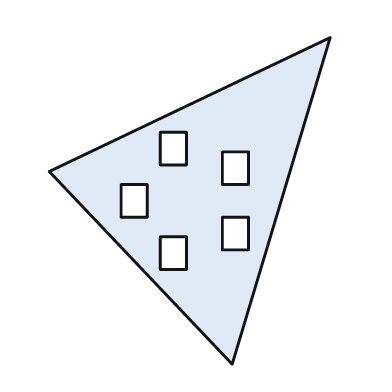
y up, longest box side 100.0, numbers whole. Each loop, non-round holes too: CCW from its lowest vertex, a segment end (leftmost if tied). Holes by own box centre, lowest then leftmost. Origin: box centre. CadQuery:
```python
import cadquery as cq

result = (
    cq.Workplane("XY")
    .moveTo(13.0, -50.0)
    .lineTo(43.0, 50.0)
    .lineTo(-43.0, 9.0)
    .close()
    .moveTo(-9.0, -21.0)
    .lineTo(-1.0, -21.0)
    .lineTo(-1.0, -11.0)
    .lineTo(-9.0, -11.0)
    .close()
    .moveTo(10.0, -15.0)
    .lineTo(18.0, -15.0)
    .lineTo(18.0, -5.0)
    .lineTo(10.0, -5.0)
    .close()
    .moveTo(-21.0, -5.0)
    .lineTo(-13.0, -5.0)
    .lineTo(-13.0, 5.0)
    .lineTo(-21.0, 5.0)
    .close()
    .moveTo(10.0, 5.0)
    .lineTo(18.0, 5.0)
    .lineTo(18.0, 15.0)
    .lineTo(10.0, 15.0)
    .close()
    .moveTo(-9.0, 11.0)
    .lineTo(-1.0, 11.0)
    .lineTo(-1.0, 21.0)
    .lineTo(-9.0, 21.0)
    .close()
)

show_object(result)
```